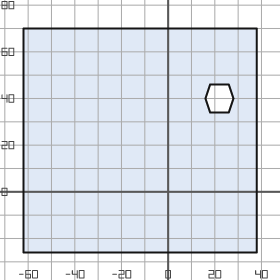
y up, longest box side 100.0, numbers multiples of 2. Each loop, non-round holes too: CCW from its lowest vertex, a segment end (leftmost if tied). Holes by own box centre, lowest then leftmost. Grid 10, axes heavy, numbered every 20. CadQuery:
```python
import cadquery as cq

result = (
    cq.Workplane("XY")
    .moveTo(-62.0, -26.0)
    .lineTo(38.0, -26.0)
    .lineTo(38.0, 70.0)
    .lineTo(-62.0, 70.0)
    .close()
    .moveTo(18.0, 34.0)
    .lineTo(26.0, 34.0)
    .lineTo(28.0, 40.0)
    .lineTo(26.0, 46.0)
    .lineTo(18.0, 46.0)
    .lineTo(16.0, 40.0)
    .close()
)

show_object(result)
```